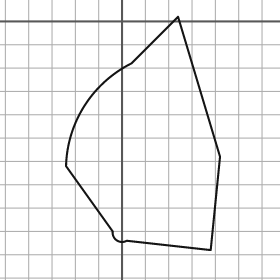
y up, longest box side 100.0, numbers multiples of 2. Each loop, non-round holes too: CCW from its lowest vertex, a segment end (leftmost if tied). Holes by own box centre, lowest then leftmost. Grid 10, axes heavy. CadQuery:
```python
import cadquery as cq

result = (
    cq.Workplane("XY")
    .moveTo(38.0, -98.0)
    .lineTo(42.0, -58.0)
    .lineTo(24.0, 2.0)
    .lineTo(4.0, -18.0)
    .threePointArc((-16.0, -36.0), (-24.0, -62.0))
    .lineTo(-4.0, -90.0)
    .threePointArc((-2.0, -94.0), (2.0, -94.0))
    .close()
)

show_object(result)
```